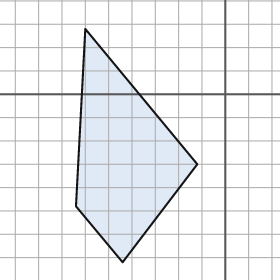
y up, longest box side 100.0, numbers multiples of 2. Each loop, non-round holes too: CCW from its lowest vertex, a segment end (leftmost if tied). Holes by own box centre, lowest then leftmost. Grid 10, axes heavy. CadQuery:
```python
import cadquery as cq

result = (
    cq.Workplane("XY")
    .moveTo(-44.0, -72.0)
    .lineTo(-12.0, -30.0)
    .lineTo(-60.0, 28.0)
    .lineTo(-64.0, -48.0)
    .close()
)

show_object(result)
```